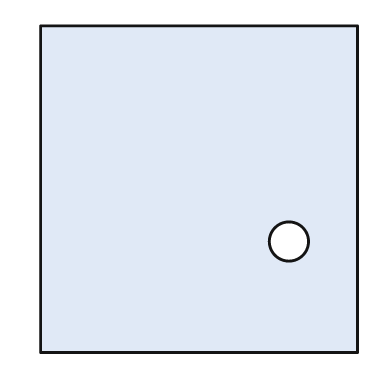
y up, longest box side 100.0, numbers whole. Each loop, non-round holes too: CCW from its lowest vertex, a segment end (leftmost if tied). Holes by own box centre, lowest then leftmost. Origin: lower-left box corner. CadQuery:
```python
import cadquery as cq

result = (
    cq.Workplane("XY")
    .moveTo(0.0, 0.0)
    .lineTo(97.0, 0.0)
    .lineTo(97.0, 100.0)
    .lineTo(0.0, 100.0)
    .close()
    .moveTo(76.0, 34.0)
    .circle(6.0)
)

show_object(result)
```